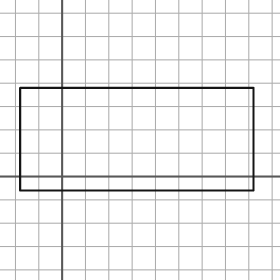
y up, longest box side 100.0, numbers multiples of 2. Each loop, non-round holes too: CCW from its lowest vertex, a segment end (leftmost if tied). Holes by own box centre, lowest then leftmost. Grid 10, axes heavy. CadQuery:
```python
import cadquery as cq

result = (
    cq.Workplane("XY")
    .moveTo(-18.0, -6.0)
    .lineTo(82.0, -6.0)
    .lineTo(82.0, 38.0)
    .lineTo(-18.0, 38.0)
    .close()
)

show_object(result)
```